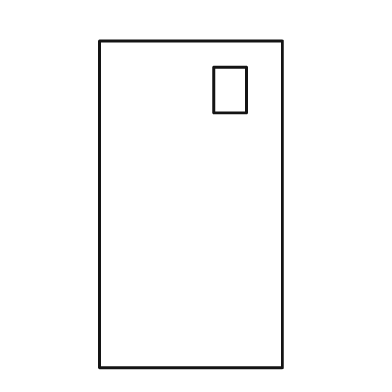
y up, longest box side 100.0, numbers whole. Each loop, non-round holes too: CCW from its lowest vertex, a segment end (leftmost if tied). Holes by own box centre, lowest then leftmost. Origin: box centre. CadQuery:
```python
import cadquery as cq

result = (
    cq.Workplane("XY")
    .moveTo(-28.0, -50.0)
    .lineTo(28.0, -50.0)
    .lineTo(28.0, 50.0)
    .lineTo(-28.0, 50.0)
    .close()
    .moveTo(7.0, 28.0)
    .lineTo(17.0, 28.0)
    .lineTo(17.0, 42.0)
    .lineTo(7.0, 42.0)
    .close()
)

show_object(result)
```